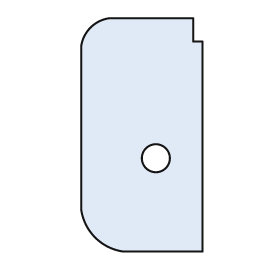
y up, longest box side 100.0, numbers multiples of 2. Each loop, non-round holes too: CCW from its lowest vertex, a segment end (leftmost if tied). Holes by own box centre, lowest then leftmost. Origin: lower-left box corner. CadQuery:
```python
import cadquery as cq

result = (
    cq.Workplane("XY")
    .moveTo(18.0, 0.0)
    .lineTo(52.0, 0.0)
    .lineTo(52.0, 90.0)
    .lineTo(48.0, 90.0)
    .lineTo(48.0, 100.0)
    .lineTo(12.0, 100.0)
    .threePointArc((4.0, 96.0), (0.0, 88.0))
    .lineTo(0.0, 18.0)
    .threePointArc((6.0, 6.0), (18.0, 0.0))
    .close()
    .moveTo(32.0, 40.0)
    .circle(6.0)
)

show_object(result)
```